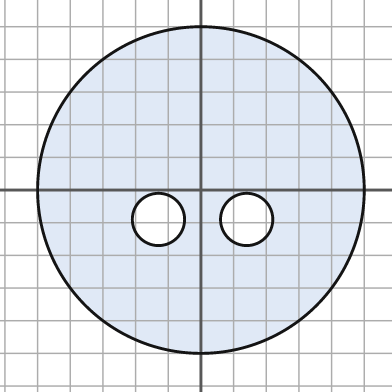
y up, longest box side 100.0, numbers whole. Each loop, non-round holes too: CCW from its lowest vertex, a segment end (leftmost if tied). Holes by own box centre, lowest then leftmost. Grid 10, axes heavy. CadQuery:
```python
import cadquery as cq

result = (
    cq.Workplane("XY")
    .moveTo(0.0, 0.0)
    .circle(50.0)
    .moveTo(-13.0, -9.0)
    .circle(8.0)
    .moveTo(14.0, -9.0)
    .circle(8.0)
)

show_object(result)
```